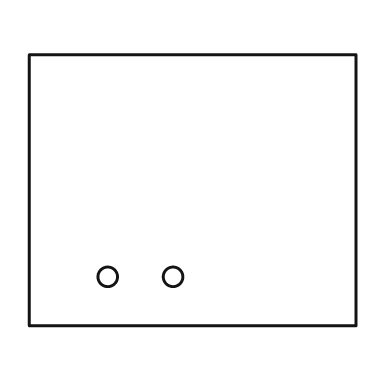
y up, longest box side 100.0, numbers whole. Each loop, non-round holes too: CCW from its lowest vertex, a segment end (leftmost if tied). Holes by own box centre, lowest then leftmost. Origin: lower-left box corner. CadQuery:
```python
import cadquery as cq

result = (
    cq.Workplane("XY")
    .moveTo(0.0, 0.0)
    .lineTo(100.0, 0.0)
    .lineTo(100.0, 83.0)
    .lineTo(0.0, 83.0)
    .close()
    .moveTo(24.0, 15.0)
    .circle(3.0)
    .moveTo(44.0, 15.0)
    .circle(3.0)
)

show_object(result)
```